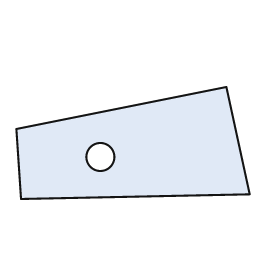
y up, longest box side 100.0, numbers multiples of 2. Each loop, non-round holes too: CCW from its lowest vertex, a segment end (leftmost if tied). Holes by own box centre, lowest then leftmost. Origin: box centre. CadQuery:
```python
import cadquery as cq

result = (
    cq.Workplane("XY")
    .moveTo(-48.0, -24.0)
    .lineTo(50.0, -22.0)
    .lineTo(40.0, 24.0)
    .lineTo(-50.0, 6.0)
    .close()
    .moveTo(-14.0, -6.0)
    .circle(6.0)
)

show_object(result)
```